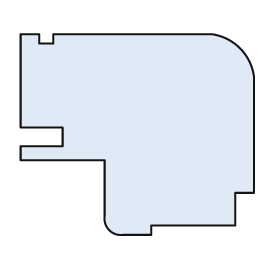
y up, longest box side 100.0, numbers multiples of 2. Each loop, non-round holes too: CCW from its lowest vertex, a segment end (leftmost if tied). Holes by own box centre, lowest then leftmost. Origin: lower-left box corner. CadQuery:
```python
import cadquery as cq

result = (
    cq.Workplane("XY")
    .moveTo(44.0, 0.0)
    .lineTo(56.0, 0.0)
    .lineTo(56.0, 4.0)
    .lineTo(92.0, 4.0)
    .lineTo(92.0, 18.0)
    .lineTo(100.0, 18.0)
    .lineTo(100.0, 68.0)
    .threePointArc((94.0, 80.0), (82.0, 86.0))
    .lineTo(14.0, 86.0)
    .lineTo(14.0, 82.0)
    .lineTo(8.0, 82.0)
    .lineTo(8.0, 86.0)
    .lineTo(0.0, 86.0)
    .lineTo(0.0, 46.0)
    .lineTo(18.0, 46.0)
    .lineTo(18.0, 38.0)
    .lineTo(0.0, 38.0)
    .lineTo(0.0, 32.0)
    .lineTo(36.0, 32.0)
    .lineTo(36.0, 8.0)
    .threePointArc((38.0, 2.0), (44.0, 0.0))
    .close()
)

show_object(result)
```